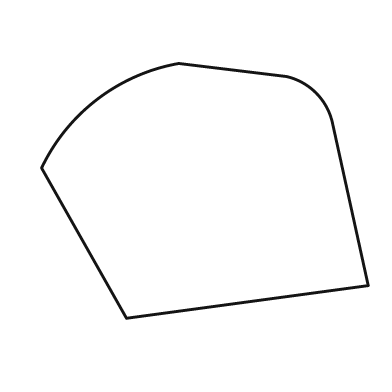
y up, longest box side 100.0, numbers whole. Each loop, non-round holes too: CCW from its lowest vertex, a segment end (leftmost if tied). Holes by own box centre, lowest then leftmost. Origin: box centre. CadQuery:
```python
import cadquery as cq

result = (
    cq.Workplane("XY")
    .moveTo(-24.0, -39.0)
    .lineTo(50.0, -29.0)
    .lineTo(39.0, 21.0)
    .threePointArc((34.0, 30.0), (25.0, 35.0))
    .lineTo(-8.0, 39.0)
    .threePointArc((-33.0, 28.0), (-50.0, 7.0))
    .close()
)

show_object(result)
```